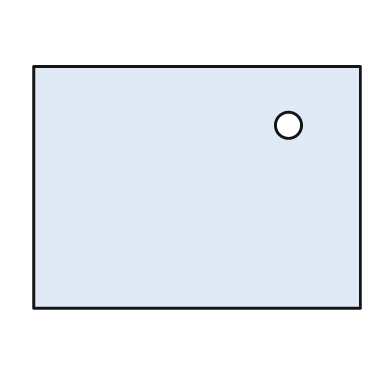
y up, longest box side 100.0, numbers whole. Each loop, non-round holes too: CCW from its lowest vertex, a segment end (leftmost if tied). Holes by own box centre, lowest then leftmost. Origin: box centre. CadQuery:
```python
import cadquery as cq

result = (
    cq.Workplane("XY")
    .moveTo(-50.0, -37.0)
    .lineTo(50.0, -37.0)
    .lineTo(50.0, 37.0)
    .lineTo(-50.0, 37.0)
    .close()
    .moveTo(28.0, 19.0)
    .circle(4.0)
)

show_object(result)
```